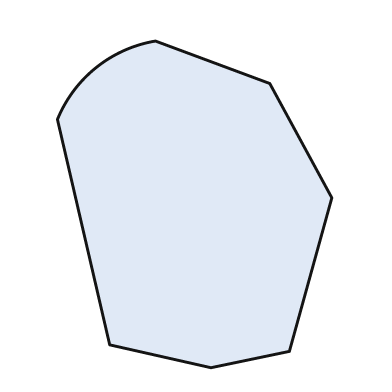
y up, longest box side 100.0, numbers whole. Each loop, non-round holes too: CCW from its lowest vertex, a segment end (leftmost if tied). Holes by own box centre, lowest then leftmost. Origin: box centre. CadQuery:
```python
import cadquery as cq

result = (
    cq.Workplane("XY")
    .moveTo(5.0, -50.0)
    .lineTo(29.0, -45.0)
    .lineTo(42.0, 2.0)
    .lineTo(23.0, 37.0)
    .lineTo(-12.0, 50.0)
    .threePointArc((-30.0, 42.0), (-42.0, 26.0))
    .lineTo(-26.0, -43.0)
    .close()
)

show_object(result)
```